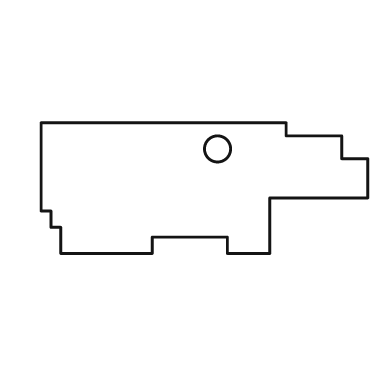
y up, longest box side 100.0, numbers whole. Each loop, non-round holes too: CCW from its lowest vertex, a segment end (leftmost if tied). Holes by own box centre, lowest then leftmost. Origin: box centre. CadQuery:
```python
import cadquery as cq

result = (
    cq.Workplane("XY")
    .moveTo(-44.0, -20.0)
    .lineTo(-16.0, -20.0)
    .lineTo(-16.0, -15.0)
    .lineTo(7.0, -15.0)
    .lineTo(7.0, -20.0)
    .lineTo(20.0, -20.0)
    .lineTo(20.0, -3.0)
    .lineTo(50.0, -3.0)
    .lineTo(50.0, 9.0)
    .lineTo(42.0, 9.0)
    .lineTo(42.0, 16.0)
    .lineTo(25.0, 16.0)
    .lineTo(25.0, 20.0)
    .lineTo(-50.0, 20.0)
    .lineTo(-50.0, -7.0)
    .lineTo(-47.0, -7.0)
    .lineTo(-47.0, -12.0)
    .lineTo(-44.0, -12.0)
    .close()
    .moveTo(4.0, 12.0)
    .circle(4.0)
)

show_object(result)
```